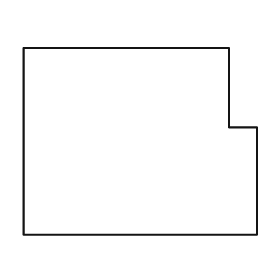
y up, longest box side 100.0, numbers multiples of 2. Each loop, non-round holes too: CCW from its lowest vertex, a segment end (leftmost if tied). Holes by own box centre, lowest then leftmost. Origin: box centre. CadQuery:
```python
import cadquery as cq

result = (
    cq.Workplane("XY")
    .moveTo(-50.0, -40.0)
    .lineTo(50.0, -40.0)
    .lineTo(50.0, 6.0)
    .lineTo(38.0, 6.0)
    .lineTo(38.0, 40.0)
    .lineTo(-50.0, 40.0)
    .close()
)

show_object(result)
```